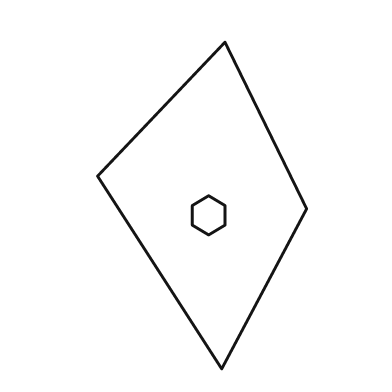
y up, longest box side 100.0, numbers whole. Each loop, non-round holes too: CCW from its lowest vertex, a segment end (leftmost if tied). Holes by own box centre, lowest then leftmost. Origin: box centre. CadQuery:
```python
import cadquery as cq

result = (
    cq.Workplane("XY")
    .moveTo(6.0, -50.0)
    .lineTo(32.0, -1.0)
    .lineTo(7.0, 50.0)
    .lineTo(-32.0, 9.0)
    .close()
    .moveTo(2.0, -9.0)
    .lineTo(7.0, -6.0)
    .lineTo(7.0, 0.0)
    .lineTo(2.0, 3.0)
    .lineTo(-3.0, 0.0)
    .lineTo(-3.0, -6.0)
    .close()
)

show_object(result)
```